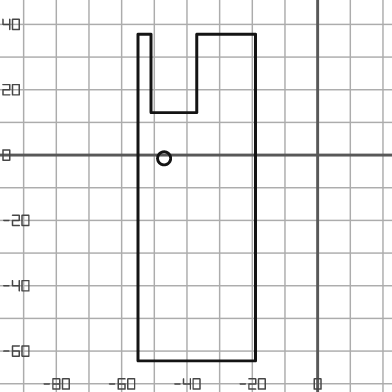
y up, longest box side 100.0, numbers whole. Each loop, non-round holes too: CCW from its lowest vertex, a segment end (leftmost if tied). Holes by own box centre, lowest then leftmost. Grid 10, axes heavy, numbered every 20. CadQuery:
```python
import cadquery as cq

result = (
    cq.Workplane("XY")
    .moveTo(-55.0, -63.0)
    .lineTo(-19.0, -63.0)
    .lineTo(-19.0, 37.0)
    .lineTo(-37.0, 37.0)
    .lineTo(-37.0, 13.0)
    .lineTo(-51.0, 13.0)
    .lineTo(-51.0, 37.0)
    .lineTo(-55.0, 37.0)
    .close()
    .moveTo(-47.0, -1.0)
    .circle(2.0)
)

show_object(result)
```